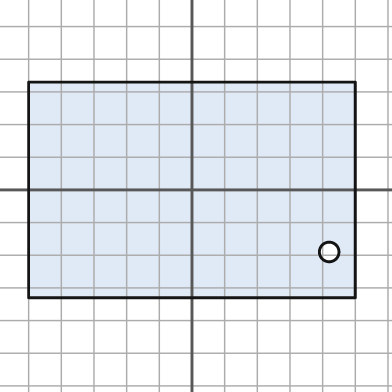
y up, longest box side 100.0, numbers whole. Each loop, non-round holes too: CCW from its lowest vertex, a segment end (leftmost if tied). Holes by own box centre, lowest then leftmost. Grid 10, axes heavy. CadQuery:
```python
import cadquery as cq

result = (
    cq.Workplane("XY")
    .moveTo(-50.0, -33.0)
    .lineTo(50.0, -33.0)
    .lineTo(50.0, 33.0)
    .lineTo(-50.0, 33.0)
    .close()
    .moveTo(42.0, -19.0)
    .circle(3.0)
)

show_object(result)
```